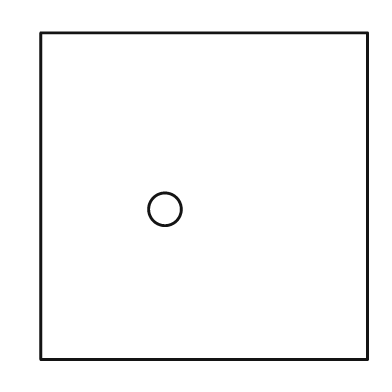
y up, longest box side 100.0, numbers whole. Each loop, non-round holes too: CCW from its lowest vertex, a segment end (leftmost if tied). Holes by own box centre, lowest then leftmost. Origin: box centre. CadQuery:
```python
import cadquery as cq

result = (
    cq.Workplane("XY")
    .moveTo(-50.0, -50.0)
    .lineTo(50.0, -50.0)
    .lineTo(50.0, 50.0)
    .lineTo(-50.0, 50.0)
    .close()
    .moveTo(-12.0, -4.0)
    .circle(5.0)
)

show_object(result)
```